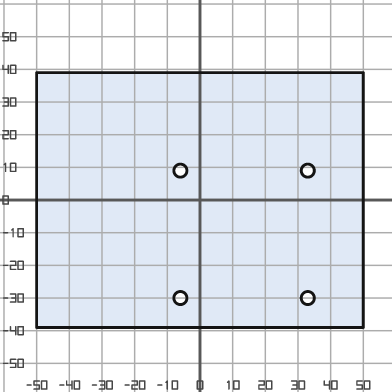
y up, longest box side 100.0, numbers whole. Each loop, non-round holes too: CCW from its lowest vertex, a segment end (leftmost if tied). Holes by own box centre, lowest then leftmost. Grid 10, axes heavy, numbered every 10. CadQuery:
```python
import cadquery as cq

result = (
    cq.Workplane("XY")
    .moveTo(-50.0, -39.0)
    .lineTo(50.0, -39.0)
    .lineTo(50.0, 39.0)
    .lineTo(-50.0, 39.0)
    .close()
    .moveTo(-6.0, -30.0)
    .circle(2.0)
    .moveTo(33.0, -30.0)
    .circle(2.0)
    .moveTo(-6.0, 9.0)
    .circle(2.0)
    .moveTo(33.0, 9.0)
    .circle(2.0)
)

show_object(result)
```